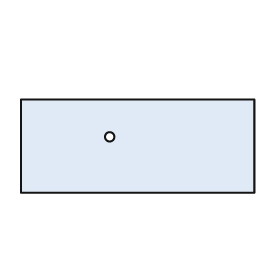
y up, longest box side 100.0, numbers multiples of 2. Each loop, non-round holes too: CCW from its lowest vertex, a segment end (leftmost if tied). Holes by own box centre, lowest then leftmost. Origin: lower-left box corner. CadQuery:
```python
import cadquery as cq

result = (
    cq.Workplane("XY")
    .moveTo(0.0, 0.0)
    .lineTo(100.0, 0.0)
    .lineTo(100.0, 40.0)
    .lineTo(0.0, 40.0)
    .close()
    .moveTo(38.0, 24.0)
    .circle(2.0)
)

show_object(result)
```